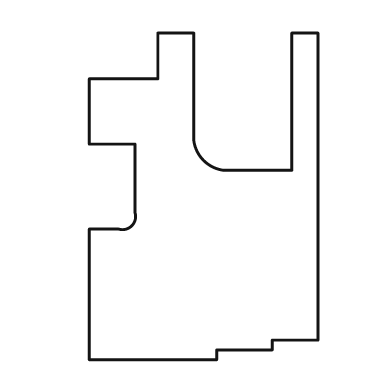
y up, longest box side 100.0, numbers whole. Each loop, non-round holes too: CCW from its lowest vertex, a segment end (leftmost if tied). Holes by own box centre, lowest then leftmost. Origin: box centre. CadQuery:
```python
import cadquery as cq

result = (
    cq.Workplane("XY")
    .moveTo(-35.0, -50.0)
    .lineTo(4.0, -50.0)
    .lineTo(4.0, -47.0)
    .lineTo(21.0, -47.0)
    .lineTo(21.0, -44.0)
    .lineTo(35.0, -44.0)
    .lineTo(35.0, 50.0)
    .lineTo(27.0, 50.0)
    .lineTo(27.0, 8.0)
    .lineTo(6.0, 8.0)
    .threePointArc((0.0, 11.0), (-3.0, 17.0))
    .lineTo(-3.0, 50.0)
    .lineTo(-14.0, 50.0)
    .lineTo(-14.0, 36.0)
    .lineTo(-35.0, 36.0)
    .lineTo(-35.0, 16.0)
    .lineTo(-21.0, 16.0)
    .lineTo(-21.0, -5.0)
    .threePointArc((-22.0, -9.0), (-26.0, -10.0))
    .lineTo(-35.0, -10.0)
    .close()
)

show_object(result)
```